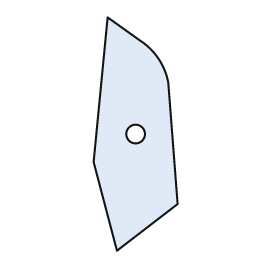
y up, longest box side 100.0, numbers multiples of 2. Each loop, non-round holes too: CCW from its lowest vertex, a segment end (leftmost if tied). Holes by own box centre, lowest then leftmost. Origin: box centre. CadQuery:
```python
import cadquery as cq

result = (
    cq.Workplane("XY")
    .moveTo(-8.0, -50.0)
    .lineTo(18.0, -30.0)
    .lineTo(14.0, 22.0)
    .threePointArc((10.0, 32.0), (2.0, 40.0))
    .lineTo(-12.0, 50.0)
    .lineTo(-18.0, -12.0)
    .close()
    .moveTo(0.0, 0.0)
    .circle(4.0)
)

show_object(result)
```